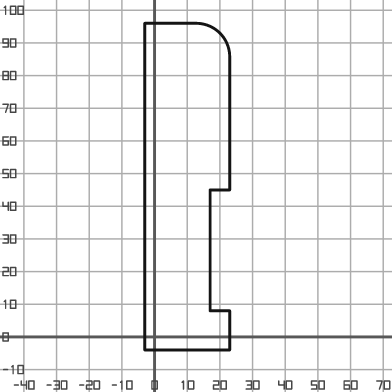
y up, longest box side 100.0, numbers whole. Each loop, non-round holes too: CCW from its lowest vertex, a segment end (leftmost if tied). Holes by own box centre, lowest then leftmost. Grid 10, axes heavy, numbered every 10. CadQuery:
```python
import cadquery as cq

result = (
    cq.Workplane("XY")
    .moveTo(-3.0, -4.0)
    .lineTo(23.0, -4.0)
    .lineTo(23.0, 8.0)
    .lineTo(17.0, 8.0)
    .lineTo(17.0, 45.0)
    .lineTo(23.0, 45.0)
    .lineTo(23.0, 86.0)
    .threePointArc((20.0, 93.0), (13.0, 96.0))
    .lineTo(-3.0, 96.0)
    .close()
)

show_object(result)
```